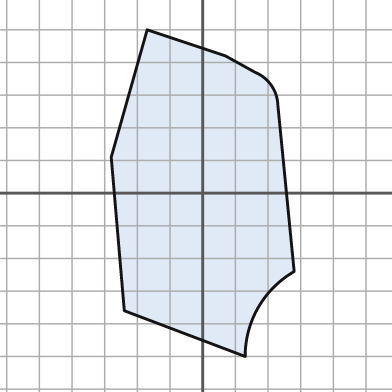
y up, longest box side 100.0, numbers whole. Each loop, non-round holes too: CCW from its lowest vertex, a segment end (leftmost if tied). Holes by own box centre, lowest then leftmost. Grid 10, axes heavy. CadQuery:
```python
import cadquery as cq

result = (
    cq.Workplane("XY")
    .moveTo(13.0, -50.0)
    .threePointArc((17.0, -35.0), (28.0, -24.0))
    .lineTo(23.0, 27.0)
    .threePointArc((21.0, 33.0), (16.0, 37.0))
    .lineTo(7.0, 42.0)
    .lineTo(-17.0, 50.0)
    .lineTo(-28.0, 11.0)
    .lineTo(-24.0, -36.0)
    .close()
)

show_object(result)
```